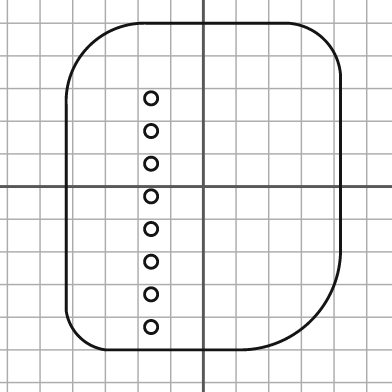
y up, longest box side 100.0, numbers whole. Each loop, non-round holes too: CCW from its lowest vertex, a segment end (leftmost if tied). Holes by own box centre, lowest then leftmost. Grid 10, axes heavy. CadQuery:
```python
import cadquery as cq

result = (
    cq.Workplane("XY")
    .moveTo(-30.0, -50.0)
    .lineTo(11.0, -50.0)
    .threePointArc((33.0, -41.0), (42.0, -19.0))
    .lineTo(42.0, 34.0)
    .threePointArc((37.0, 45.0), (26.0, 50.0))
    .lineTo(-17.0, 50.0)
    .threePointArc((-35.0, 43.0), (-42.0, 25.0))
    .lineTo(-42.0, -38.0)
    .threePointArc((-38.0, -46.0), (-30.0, -50.0))
    .close()
    .moveTo(-16.0, -43.0)
    .circle(2.0)
    .moveTo(-16.0, -33.0)
    .circle(2.0)
    .moveTo(-16.0, -23.0)
    .circle(2.0)
    .moveTo(-16.0, -13.0)
    .circle(2.0)
    .moveTo(-16.0, -3.0)
    .circle(2.0)
    .moveTo(-16.0, 7.0)
    .circle(2.0)
    .moveTo(-16.0, 17.0)
    .circle(2.0)
    .moveTo(-16.0, 27.0)
    .circle(2.0)
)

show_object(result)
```